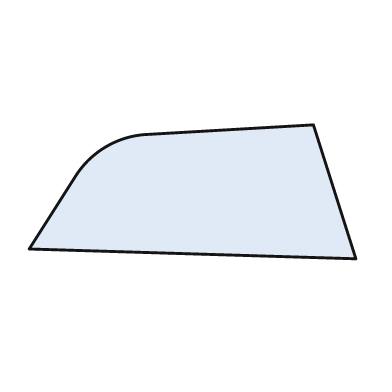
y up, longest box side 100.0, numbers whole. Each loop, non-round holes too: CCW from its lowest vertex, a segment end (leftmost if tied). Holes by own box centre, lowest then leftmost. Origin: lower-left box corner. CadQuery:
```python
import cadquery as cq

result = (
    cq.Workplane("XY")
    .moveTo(100.0, 0.0)
    .lineTo(87.0, 41.0)
    .lineTo(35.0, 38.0)
    .threePointArc((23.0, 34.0), (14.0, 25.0))
    .lineTo(0.0, 3.0)
    .close()
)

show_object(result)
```